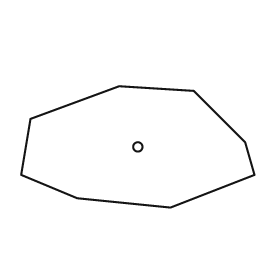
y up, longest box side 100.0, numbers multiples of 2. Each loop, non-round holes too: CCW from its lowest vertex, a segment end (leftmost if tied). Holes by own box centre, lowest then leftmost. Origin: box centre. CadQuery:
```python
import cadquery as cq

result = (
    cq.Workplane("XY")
    .moveTo(14.0, -26.0)
    .lineTo(50.0, -12.0)
    .lineTo(46.0, 2.0)
    .lineTo(24.0, 24.0)
    .lineTo(-8.0, 26.0)
    .lineTo(-46.0, 12.0)
    .lineTo(-50.0, -12.0)
    .lineTo(-26.0, -22.0)
    .close()
    .moveTo(0.0, 0.0)
    .circle(2.0)
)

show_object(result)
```